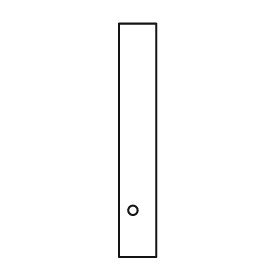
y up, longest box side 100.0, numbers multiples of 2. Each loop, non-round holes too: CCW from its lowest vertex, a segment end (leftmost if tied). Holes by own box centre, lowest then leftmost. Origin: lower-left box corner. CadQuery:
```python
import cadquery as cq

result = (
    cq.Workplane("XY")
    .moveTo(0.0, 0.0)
    .lineTo(16.0, 0.0)
    .lineTo(16.0, 100.0)
    .lineTo(0.0, 100.0)
    .close()
    .moveTo(6.0, 20.0)
    .circle(2.0)
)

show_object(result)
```